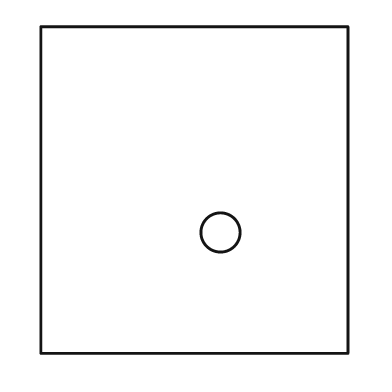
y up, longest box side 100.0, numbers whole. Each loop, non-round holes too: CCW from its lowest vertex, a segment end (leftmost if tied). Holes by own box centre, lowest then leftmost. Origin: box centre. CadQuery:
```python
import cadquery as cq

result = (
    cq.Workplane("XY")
    .moveTo(-47.0, -50.0)
    .lineTo(47.0, -50.0)
    .lineTo(47.0, 50.0)
    .lineTo(-47.0, 50.0)
    .close()
    .moveTo(8.0, -13.0)
    .circle(6.0)
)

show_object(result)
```